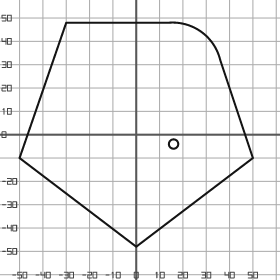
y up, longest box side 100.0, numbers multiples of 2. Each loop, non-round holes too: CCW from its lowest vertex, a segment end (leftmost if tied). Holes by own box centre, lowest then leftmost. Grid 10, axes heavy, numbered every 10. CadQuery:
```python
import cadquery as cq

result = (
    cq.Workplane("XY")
    .moveTo(0.0, -48.0)
    .lineTo(50.0, -10.0)
    .lineTo(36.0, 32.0)
    .threePointArc((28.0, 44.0), (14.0, 48.0))
    .lineTo(-30.0, 48.0)
    .lineTo(-50.0, -10.0)
    .close()
    .moveTo(16.0, -4.0)
    .circle(2.0)
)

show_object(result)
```